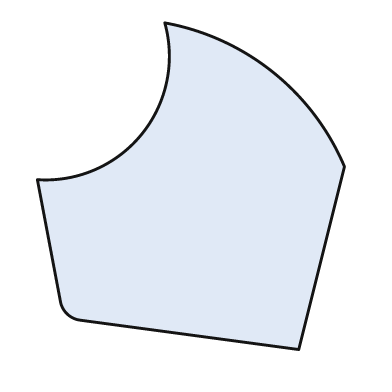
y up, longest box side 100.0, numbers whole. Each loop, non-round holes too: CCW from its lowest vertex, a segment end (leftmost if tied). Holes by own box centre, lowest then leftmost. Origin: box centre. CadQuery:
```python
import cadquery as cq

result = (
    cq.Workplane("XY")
    .moveTo(33.0, -50.0)
    .lineTo(47.0, 6.0)
    .threePointArc((25.0, 35.0), (-8.0, 50.0))
    .threePointArc((-15.0, 16.0), (-47.0, 2.0))
    .lineTo(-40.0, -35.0)
    .threePointArc((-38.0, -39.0), (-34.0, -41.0))
    .close()
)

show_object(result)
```